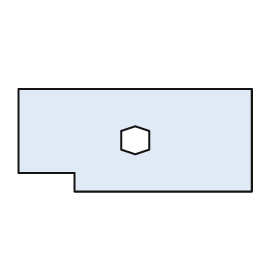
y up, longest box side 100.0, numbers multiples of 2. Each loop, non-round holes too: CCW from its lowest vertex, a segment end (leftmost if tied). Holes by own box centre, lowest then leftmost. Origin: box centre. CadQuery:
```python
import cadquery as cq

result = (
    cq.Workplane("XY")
    .moveTo(-26.0, -22.0)
    .lineTo(50.0, -22.0)
    .lineTo(50.0, 22.0)
    .lineTo(-50.0, 22.0)
    .lineTo(-50.0, -14.0)
    .lineTo(-26.0, -14.0)
    .close()
    .moveTo(0.0, -6.0)
    .lineTo(6.0, -4.0)
    .lineTo(6.0, 4.0)
    .lineTo(0.0, 6.0)
    .lineTo(-6.0, 4.0)
    .lineTo(-6.0, -4.0)
    .close()
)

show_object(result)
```